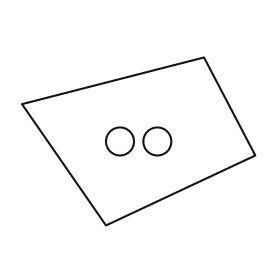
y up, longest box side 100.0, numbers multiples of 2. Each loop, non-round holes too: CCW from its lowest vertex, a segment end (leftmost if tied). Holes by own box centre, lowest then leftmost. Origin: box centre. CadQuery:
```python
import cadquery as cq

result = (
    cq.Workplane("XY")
    .moveTo(-14.0, -36.0)
    .lineTo(50.0, -6.0)
    .lineTo(28.0, 36.0)
    .lineTo(-50.0, 16.0)
    .close()
    .moveTo(-8.0, 0.0)
    .circle(6.0)
    .moveTo(8.0, 0.0)
    .circle(6.0)
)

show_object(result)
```